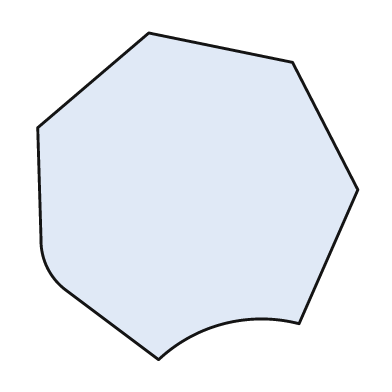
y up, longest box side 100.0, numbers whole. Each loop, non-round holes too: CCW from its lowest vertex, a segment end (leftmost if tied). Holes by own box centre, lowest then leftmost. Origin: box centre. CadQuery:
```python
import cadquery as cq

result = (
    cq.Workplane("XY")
    .moveTo(-12.0, -50.0)
    .threePointArc((8.0, -39.0), (31.0, -39.0))
    .lineTo(49.0, 2.0)
    .lineTo(29.0, 41.0)
    .lineTo(-15.0, 50.0)
    .lineTo(-49.0, 21.0)
    .lineTo(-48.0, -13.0)
    .threePointArc((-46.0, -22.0), (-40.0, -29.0))
    .close()
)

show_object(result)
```